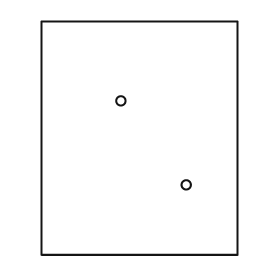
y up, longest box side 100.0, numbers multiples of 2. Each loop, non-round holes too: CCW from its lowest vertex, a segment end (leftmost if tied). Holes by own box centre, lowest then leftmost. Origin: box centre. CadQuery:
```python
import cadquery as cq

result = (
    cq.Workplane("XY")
    .moveTo(-42.0, -50.0)
    .lineTo(42.0, -50.0)
    .lineTo(42.0, 50.0)
    .lineTo(-42.0, 50.0)
    .close()
    .moveTo(20.0, -20.0)
    .circle(2.0)
    .moveTo(-8.0, 16.0)
    .circle(2.0)
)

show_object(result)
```